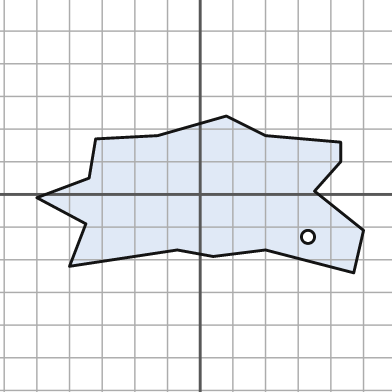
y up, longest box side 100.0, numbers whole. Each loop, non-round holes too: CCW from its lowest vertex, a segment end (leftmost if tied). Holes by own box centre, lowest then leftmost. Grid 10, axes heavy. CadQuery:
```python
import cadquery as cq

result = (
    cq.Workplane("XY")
    .moveTo(47.0, -24.0)
    .lineTo(50.0, -11.0)
    .lineTo(35.0, 1.0)
    .lineTo(43.0, 10.0)
    .lineTo(43.0, 16.0)
    .lineTo(20.0, 18.0)
    .lineTo(8.0, 24.0)
    .lineTo(-13.0, 18.0)
    .lineTo(-32.0, 17.0)
    .lineTo(-34.0, 5.0)
    .lineTo(-50.0, -1.0)
    .lineTo(-35.0, -9.0)
    .lineTo(-40.0, -22.0)
    .lineTo(-7.0, -17.0)
    .lineTo(4.0, -19.0)
    .lineTo(20.0, -17.0)
    .close()
    .moveTo(33.0, -13.0)
    .circle(2.0)
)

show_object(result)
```